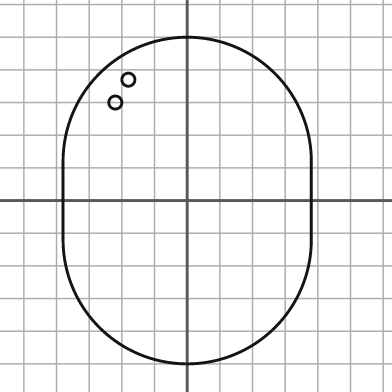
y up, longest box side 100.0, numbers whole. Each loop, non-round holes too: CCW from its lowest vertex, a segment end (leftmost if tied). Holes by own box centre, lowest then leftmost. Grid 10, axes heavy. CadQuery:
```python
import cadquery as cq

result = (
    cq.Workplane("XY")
    .moveTo(-38.0, -12.0)
    .threePointArc((0.0, -50.0), (38.0, -12.0))
    .lineTo(38.0, 12.0)
    .threePointArc((0.0, 50.0), (-38.0, 12.0))
    .close()
    .moveTo(-22.0, 30.0)
    .circle(2.0)
    .moveTo(-18.0, 37.0)
    .circle(2.0)
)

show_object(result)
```